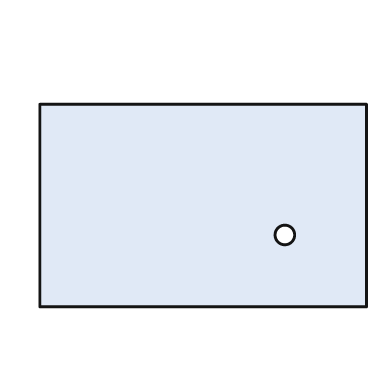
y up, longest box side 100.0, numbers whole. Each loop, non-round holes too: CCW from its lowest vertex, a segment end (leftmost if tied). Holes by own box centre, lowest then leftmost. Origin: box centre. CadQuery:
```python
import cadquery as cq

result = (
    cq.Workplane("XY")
    .moveTo(-50.0, -31.0)
    .lineTo(50.0, -31.0)
    .lineTo(50.0, 31.0)
    .lineTo(-50.0, 31.0)
    .close()
    .moveTo(25.0, -9.0)
    .circle(3.0)
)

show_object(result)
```